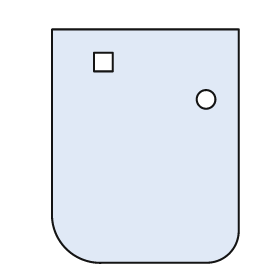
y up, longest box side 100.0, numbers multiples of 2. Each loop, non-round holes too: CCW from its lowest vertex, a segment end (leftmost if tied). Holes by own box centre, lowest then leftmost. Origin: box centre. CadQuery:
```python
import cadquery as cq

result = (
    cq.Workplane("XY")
    .moveTo(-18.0, -50.0)
    .lineTo(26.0, -50.0)
    .threePointArc((36.0, -46.0), (40.0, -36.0))
    .lineTo(40.0, 50.0)
    .lineTo(-40.0, 50.0)
    .lineTo(-40.0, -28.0)
    .threePointArc((-34.0, -44.0), (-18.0, -50.0))
    .close()
    .moveTo(26.0, 20.0)
    .circle(4.0)
    .moveTo(-22.0, 32.0)
    .lineTo(-14.0, 32.0)
    .lineTo(-14.0, 40.0)
    .lineTo(-22.0, 40.0)
    .close()
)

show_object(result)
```